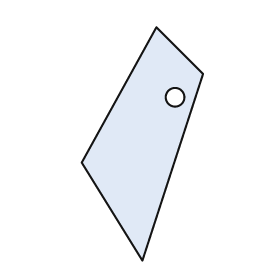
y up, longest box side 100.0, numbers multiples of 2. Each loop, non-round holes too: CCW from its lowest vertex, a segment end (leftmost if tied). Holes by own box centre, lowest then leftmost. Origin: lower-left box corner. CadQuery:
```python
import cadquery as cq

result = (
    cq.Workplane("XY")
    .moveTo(26.0, 0.0)
    .lineTo(52.0, 80.0)
    .lineTo(32.0, 100.0)
    .lineTo(0.0, 42.0)
    .close()
    .moveTo(40.0, 70.0)
    .circle(4.0)
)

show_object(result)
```